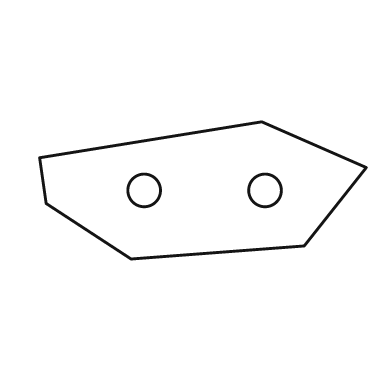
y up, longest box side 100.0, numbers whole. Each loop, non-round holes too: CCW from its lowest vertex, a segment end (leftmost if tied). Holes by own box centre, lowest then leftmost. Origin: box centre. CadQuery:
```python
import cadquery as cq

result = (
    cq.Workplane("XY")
    .moveTo(-22.0, -21.0)
    .lineTo(31.0, -17.0)
    .lineTo(50.0, 7.0)
    .lineTo(18.0, 21.0)
    .lineTo(-50.0, 10.0)
    .lineTo(-48.0, -4.0)
    .close()
    .moveTo(-18.0, 0.0)
    .circle(5.0)
    .moveTo(19.0, 0.0)
    .circle(5.0)
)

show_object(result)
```